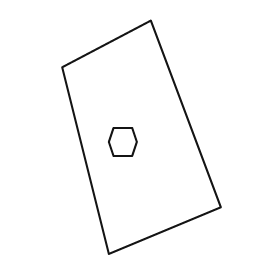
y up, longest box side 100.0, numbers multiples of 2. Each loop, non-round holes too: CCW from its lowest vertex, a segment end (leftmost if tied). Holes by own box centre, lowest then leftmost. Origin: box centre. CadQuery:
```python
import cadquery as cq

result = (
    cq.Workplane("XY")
    .moveTo(-14.0, -50.0)
    .lineTo(34.0, -30.0)
    .lineTo(4.0, 50.0)
    .lineTo(-34.0, 30.0)
    .close()
    .moveTo(-12.0, -8.0)
    .lineTo(-4.0, -8.0)
    .lineTo(-2.0, -2.0)
    .lineTo(-4.0, 4.0)
    .lineTo(-12.0, 4.0)
    .lineTo(-14.0, -2.0)
    .close()
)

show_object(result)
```